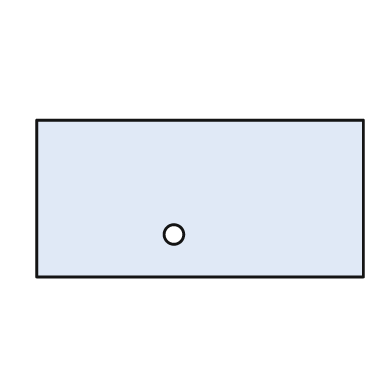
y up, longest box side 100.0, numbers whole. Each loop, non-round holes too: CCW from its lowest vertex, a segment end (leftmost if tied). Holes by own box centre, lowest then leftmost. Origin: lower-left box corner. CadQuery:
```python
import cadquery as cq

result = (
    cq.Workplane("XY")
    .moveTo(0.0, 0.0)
    .lineTo(100.0, 0.0)
    .lineTo(100.0, 48.0)
    .lineTo(0.0, 48.0)
    .close()
    .moveTo(42.0, 13.0)
    .circle(3.0)
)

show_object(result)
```